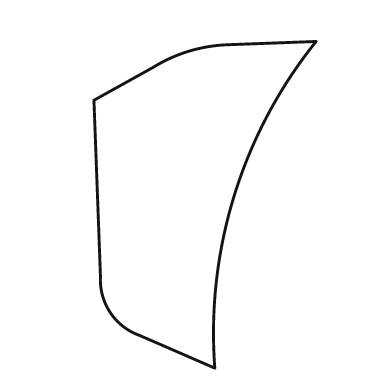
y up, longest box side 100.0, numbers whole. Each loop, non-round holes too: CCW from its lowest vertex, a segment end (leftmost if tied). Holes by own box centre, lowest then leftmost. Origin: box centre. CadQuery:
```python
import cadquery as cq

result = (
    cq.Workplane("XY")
    .moveTo(3.0, -50.0)
    .threePointArc((9.0, 3.0), (34.0, 50.0))
    .lineTo(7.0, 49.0)
    .threePointArc((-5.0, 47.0), (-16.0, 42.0))
    .lineTo(-34.0, 32.0)
    .lineTo(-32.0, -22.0)
    .threePointArc((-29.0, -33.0), (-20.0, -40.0))
    .close()
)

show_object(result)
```